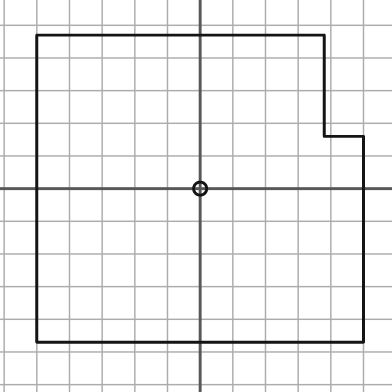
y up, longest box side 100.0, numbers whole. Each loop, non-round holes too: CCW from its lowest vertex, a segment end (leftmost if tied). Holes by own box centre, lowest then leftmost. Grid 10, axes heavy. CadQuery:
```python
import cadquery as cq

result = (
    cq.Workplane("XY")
    .moveTo(-50.0, -47.0)
    .lineTo(50.0, -47.0)
    .lineTo(50.0, 16.0)
    .lineTo(38.0, 16.0)
    .lineTo(38.0, 47.0)
    .lineTo(-50.0, 47.0)
    .close()
    .moveTo(0.0, 0.0)
    .circle(2.0)
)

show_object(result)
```